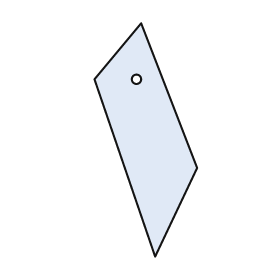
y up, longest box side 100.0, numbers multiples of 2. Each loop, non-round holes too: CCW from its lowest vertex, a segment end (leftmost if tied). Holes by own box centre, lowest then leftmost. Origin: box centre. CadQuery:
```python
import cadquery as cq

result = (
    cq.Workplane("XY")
    .moveTo(4.0, -50.0)
    .lineTo(22.0, -12.0)
    .lineTo(-2.0, 50.0)
    .lineTo(-22.0, 26.0)
    .close()
    .moveTo(-4.0, 26.0)
    .circle(2.0)
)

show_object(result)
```